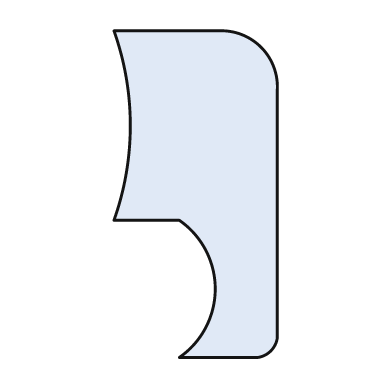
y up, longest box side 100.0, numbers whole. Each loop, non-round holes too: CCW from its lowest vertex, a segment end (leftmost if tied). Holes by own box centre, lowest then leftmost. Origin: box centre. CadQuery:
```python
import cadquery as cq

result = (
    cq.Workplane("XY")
    .moveTo(-5.0, -50.0)
    .lineTo(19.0, -50.0)
    .threePointArc((23.0, -48.0), (25.0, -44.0))
    .lineTo(25.0, 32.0)
    .threePointArc((20.0, 45.0), (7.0, 50.0))
    .lineTo(-25.0, 50.0)
    .threePointArc((-20.0, 21.0), (-25.0, -8.0))
    .lineTo(-5.0, -8.0)
    .threePointArc((6.0, -29.0), (-5.0, -50.0))
    .close()
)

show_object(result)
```